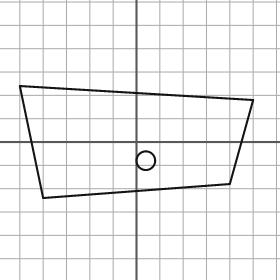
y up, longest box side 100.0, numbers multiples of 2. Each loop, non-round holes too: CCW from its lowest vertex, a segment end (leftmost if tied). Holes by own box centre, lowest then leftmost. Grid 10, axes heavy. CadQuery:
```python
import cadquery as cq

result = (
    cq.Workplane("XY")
    .moveTo(-40.0, -24.0)
    .lineTo(40.0, -18.0)
    .lineTo(50.0, 18.0)
    .lineTo(-50.0, 24.0)
    .close()
    .moveTo(4.0, -8.0)
    .circle(4.0)
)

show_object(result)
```